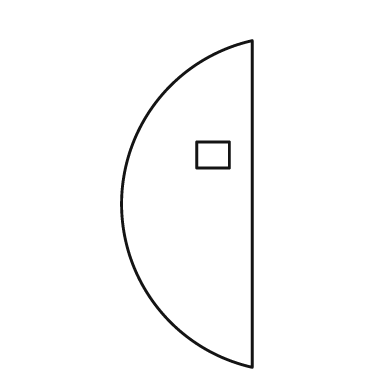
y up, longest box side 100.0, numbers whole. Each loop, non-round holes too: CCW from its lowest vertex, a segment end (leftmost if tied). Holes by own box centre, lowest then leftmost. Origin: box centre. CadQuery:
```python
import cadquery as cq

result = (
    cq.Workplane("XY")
    .moveTo(20.0, -50.0)
    .lineTo(20.0, 50.0)
    .threePointArc((-20.0, 0.0), (20.0, -50.0))
    .close()
    .moveTo(3.0, 11.0)
    .lineTo(13.0, 11.0)
    .lineTo(13.0, 19.0)
    .lineTo(3.0, 19.0)
    .close()
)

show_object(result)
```